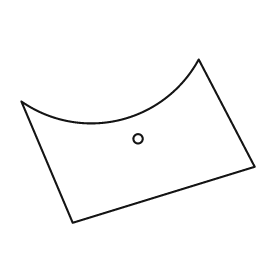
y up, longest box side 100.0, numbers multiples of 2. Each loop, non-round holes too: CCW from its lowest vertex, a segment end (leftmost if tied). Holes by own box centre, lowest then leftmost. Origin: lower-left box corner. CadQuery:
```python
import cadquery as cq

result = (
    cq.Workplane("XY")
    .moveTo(22.0, 0.0)
    .lineTo(100.0, 24.0)
    .lineTo(76.0, 70.0)
    .threePointArc((42.0, 44.0), (0.0, 52.0))
    .close()
    .moveTo(50.0, 36.0)
    .circle(2.0)
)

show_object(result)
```